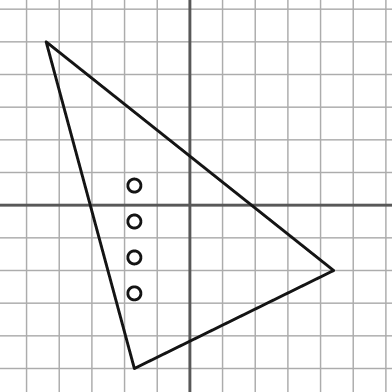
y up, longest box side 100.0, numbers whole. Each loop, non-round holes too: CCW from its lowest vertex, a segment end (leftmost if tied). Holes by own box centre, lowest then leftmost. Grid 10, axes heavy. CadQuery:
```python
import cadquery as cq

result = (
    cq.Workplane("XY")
    .moveTo(-17.0, -50.0)
    .lineTo(44.0, -20.0)
    .lineTo(-44.0, 50.0)
    .close()
    .moveTo(-17.0, -27.0)
    .circle(2.0)
    .moveTo(-17.0, -16.0)
    .circle(2.0)
    .moveTo(-17.0, -5.0)
    .circle(2.0)
    .moveTo(-17.0, 6.0)
    .circle(2.0)
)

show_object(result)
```